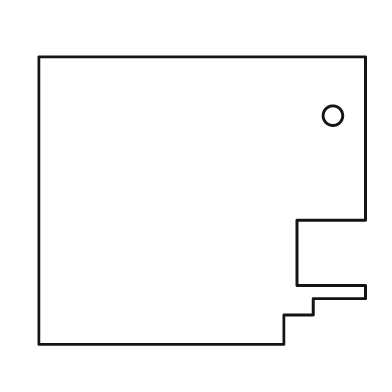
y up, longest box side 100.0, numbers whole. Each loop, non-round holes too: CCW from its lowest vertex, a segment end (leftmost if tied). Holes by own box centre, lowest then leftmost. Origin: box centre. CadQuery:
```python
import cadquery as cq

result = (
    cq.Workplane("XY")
    .moveTo(-50.0, -44.0)
    .lineTo(25.0, -44.0)
    .lineTo(25.0, -35.0)
    .lineTo(34.0, -35.0)
    .lineTo(34.0, -30.0)
    .lineTo(50.0, -30.0)
    .lineTo(50.0, -26.0)
    .lineTo(29.0, -26.0)
    .lineTo(29.0, -6.0)
    .lineTo(50.0, -6.0)
    .lineTo(50.0, 44.0)
    .lineTo(-50.0, 44.0)
    .close()
    .moveTo(40.0, 26.0)
    .circle(3.0)
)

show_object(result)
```